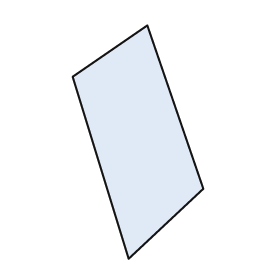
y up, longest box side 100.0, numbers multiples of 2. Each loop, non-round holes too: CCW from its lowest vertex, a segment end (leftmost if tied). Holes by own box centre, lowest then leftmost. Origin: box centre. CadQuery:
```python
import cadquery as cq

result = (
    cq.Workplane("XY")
    .moveTo(-4.0, -50.0)
    .lineTo(28.0, -20.0)
    .lineTo(4.0, 50.0)
    .lineTo(-28.0, 28.0)
    .close()
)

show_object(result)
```